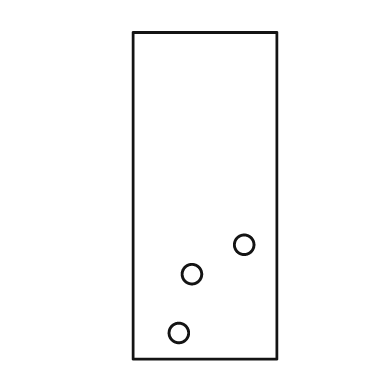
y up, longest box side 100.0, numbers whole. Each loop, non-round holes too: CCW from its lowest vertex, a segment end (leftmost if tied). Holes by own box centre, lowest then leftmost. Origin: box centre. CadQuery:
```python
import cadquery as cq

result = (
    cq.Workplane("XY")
    .moveTo(-22.0, -50.0)
    .lineTo(22.0, -50.0)
    .lineTo(22.0, 50.0)
    .lineTo(-22.0, 50.0)
    .close()
    .moveTo(-8.0, -42.0)
    .circle(3.0)
    .moveTo(-4.0, -24.0)
    .circle(3.0)
    .moveTo(12.0, -15.0)
    .circle(3.0)
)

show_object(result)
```